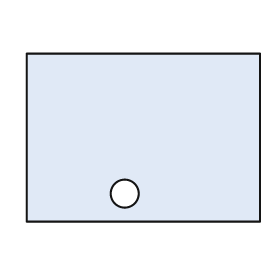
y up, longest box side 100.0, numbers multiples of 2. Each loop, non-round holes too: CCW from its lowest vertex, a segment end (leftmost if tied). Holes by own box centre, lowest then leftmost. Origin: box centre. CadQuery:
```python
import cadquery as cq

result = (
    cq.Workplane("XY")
    .moveTo(-50.0, -36.0)
    .lineTo(50.0, -36.0)
    .lineTo(50.0, 36.0)
    .lineTo(-50.0, 36.0)
    .close()
    .moveTo(-8.0, -24.0)
    .circle(6.0)
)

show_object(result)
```